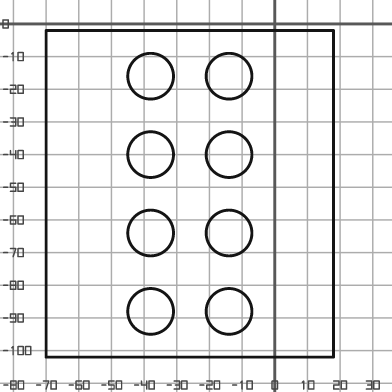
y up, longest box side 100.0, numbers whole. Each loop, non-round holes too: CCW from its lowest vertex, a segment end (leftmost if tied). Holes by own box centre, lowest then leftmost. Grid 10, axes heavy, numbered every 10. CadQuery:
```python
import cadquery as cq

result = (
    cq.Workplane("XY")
    .moveTo(-70.0, -102.0)
    .lineTo(18.0, -102.0)
    .lineTo(18.0, -2.0)
    .lineTo(-70.0, -2.0)
    .close()
    .moveTo(-38.0, -88.0)
    .circle(7.0)
    .moveTo(-14.0, -88.0)
    .circle(7.0)
    .moveTo(-38.0, -64.0)
    .circle(7.0)
    .moveTo(-14.0, -64.0)
    .circle(7.0)
    .moveTo(-38.0, -40.0)
    .circle(7.0)
    .moveTo(-14.0, -40.0)
    .circle(7.0)
    .moveTo(-38.0, -16.0)
    .circle(7.0)
    .moveTo(-14.0, -16.0)
    .circle(7.0)
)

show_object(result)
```